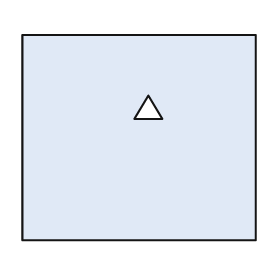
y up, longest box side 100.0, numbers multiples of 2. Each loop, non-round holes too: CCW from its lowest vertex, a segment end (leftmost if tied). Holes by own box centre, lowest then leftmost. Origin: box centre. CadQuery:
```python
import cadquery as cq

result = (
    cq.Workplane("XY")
    .moveTo(-50.0, -44.0)
    .lineTo(50.0, -44.0)
    .lineTo(50.0, 44.0)
    .lineTo(-50.0, 44.0)
    .close()
    .moveTo(-2.0, 8.0)
    .lineTo(10.0, 8.0)
    .lineTo(4.0, 18.0)
    .close()
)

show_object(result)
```